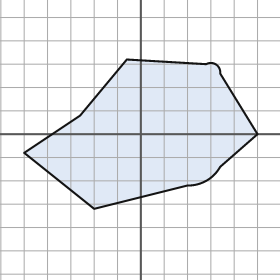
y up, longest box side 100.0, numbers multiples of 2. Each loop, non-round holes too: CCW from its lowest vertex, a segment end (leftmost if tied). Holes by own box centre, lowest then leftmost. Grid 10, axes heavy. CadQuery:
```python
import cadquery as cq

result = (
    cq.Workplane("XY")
    .moveTo(-20.0, -32.0)
    .lineTo(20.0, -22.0)
    .threePointArc((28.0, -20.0), (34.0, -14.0))
    .lineTo(50.0, 0.0)
    .lineTo(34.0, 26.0)
    .threePointArc((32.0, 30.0), (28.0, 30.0))
    .lineTo(-6.0, 32.0)
    .lineTo(-26.0, 8.0)
    .lineTo(-50.0, -8.0)
    .close()
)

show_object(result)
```